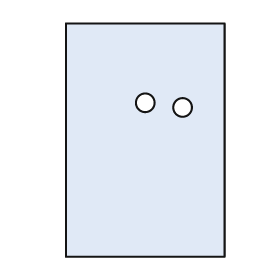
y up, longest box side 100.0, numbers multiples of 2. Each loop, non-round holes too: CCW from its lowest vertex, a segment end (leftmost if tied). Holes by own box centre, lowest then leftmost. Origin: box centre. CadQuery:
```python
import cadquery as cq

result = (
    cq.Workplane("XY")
    .moveTo(-34.0, -50.0)
    .lineTo(34.0, -50.0)
    .lineTo(34.0, 50.0)
    .lineTo(-34.0, 50.0)
    .close()
    .moveTo(16.0, 14.0)
    .circle(4.0)
    .moveTo(0.0, 16.0)
    .circle(4.0)
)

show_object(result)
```